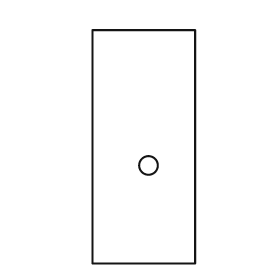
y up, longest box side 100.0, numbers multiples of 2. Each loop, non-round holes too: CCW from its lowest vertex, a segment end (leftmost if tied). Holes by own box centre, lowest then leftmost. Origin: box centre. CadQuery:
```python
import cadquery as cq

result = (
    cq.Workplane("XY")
    .moveTo(-22.0, -50.0)
    .lineTo(22.0, -50.0)
    .lineTo(22.0, 50.0)
    .lineTo(-22.0, 50.0)
    .close()
    .moveTo(2.0, -8.0)
    .circle(4.0)
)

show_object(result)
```